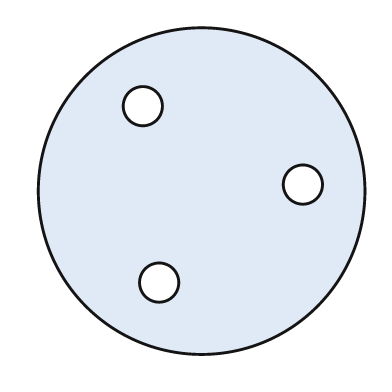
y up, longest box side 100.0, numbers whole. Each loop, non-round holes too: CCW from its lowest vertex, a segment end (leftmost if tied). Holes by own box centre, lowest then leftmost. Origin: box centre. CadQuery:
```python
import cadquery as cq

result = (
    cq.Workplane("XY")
    .moveTo(0.0, 0.0)
    .circle(50.0)
    .moveTo(-13.0, -28.0)
    .circle(6.0)
    .moveTo(31.0, 2.0)
    .circle(6.0)
    .moveTo(-18.0, 26.0)
    .circle(6.0)
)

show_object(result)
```